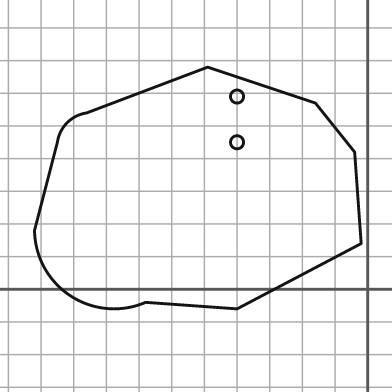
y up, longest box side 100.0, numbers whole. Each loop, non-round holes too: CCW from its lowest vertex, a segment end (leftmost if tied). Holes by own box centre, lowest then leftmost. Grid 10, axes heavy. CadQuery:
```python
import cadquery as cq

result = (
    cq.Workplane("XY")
    .moveTo(-40.0, -6.0)
    .lineTo(-2.0, 14.0)
    .lineTo(-4.0, 42.0)
    .lineTo(-16.0, 57.0)
    .lineTo(-49.0, 68.0)
    .lineTo(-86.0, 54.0)
    .threePointArc((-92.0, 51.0), (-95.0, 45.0))
    .lineTo(-102.0, 18.0)
    .threePointArc((-91.0, -2.0), (-68.0, -4.0))
    .close()
    .moveTo(-40.0, 45.0)
    .circle(2.0)
    .moveTo(-40.0, 59.0)
    .circle(2.0)
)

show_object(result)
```